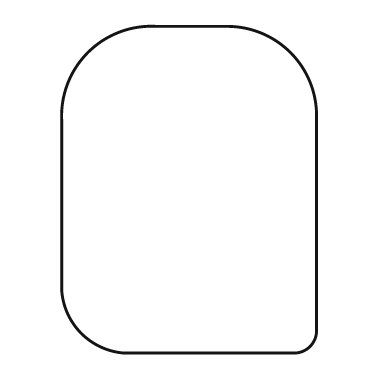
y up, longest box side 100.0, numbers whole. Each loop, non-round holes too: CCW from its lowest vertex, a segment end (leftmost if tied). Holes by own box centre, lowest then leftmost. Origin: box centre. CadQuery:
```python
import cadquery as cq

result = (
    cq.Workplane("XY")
    .moveTo(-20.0, -50.0)
    .lineTo(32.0, -50.0)
    .threePointArc((37.0, -48.0), (39.0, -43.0))
    .lineTo(39.0, 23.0)
    .threePointArc((31.0, 42.0), (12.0, 50.0))
    .lineTo(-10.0, 50.0)
    .threePointArc((-31.0, 42.0), (-39.0, 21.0))
    .lineTo(-39.0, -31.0)
    .threePointArc((-33.0, -44.0), (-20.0, -50.0))
    .close()
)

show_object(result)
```